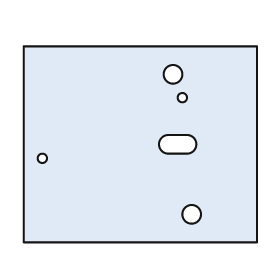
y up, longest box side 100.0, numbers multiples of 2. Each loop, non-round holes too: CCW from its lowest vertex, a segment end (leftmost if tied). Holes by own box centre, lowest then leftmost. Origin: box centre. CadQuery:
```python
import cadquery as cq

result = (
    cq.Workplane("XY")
    .moveTo(-50.0, -42.0)
    .lineTo(50.0, -42.0)
    .lineTo(50.0, 42.0)
    .lineTo(-50.0, 42.0)
    .close()
    .moveTo(22.0, -30.0)
    .circle(4.0)
    .moveTo(-42.0, -6.0)
    .circle(2.0)
    .moveTo(12.0, -4.0)
    .lineTo(20.0, -4.0)
    .threePointArc((24.0, 0.0), (20.0, 4.0))
    .lineTo(12.0, 4.0)
    .threePointArc((8.0, 0.0), (12.0, -4.0))
    .close()
    .moveTo(18.0, 20.0)
    .circle(2.0)
    .moveTo(14.0, 30.0)
    .circle(4.0)
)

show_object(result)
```